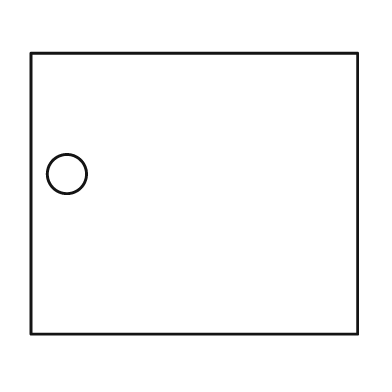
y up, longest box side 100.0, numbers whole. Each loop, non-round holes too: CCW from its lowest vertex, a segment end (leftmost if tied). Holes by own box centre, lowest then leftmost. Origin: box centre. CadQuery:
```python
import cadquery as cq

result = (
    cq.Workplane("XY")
    .moveTo(-50.0, -43.0)
    .lineTo(50.0, -43.0)
    .lineTo(50.0, 43.0)
    .lineTo(-50.0, 43.0)
    .close()
    .moveTo(-39.0, 6.0)
    .circle(6.0)
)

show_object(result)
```